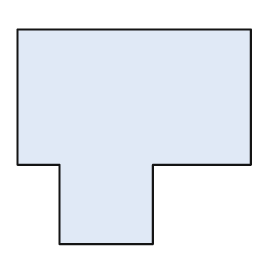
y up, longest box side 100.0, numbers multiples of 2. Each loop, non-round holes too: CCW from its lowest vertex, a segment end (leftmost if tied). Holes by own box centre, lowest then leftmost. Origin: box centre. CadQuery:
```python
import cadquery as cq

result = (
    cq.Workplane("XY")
    .moveTo(-32.0, -46.0)
    .lineTo(8.0, -46.0)
    .lineTo(8.0, -12.0)
    .lineTo(50.0, -12.0)
    .lineTo(50.0, 46.0)
    .lineTo(-50.0, 46.0)
    .lineTo(-50.0, -12.0)
    .lineTo(-32.0, -12.0)
    .close()
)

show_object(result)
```